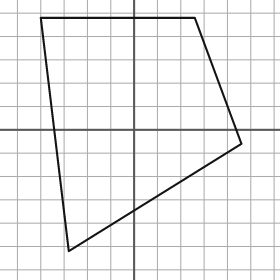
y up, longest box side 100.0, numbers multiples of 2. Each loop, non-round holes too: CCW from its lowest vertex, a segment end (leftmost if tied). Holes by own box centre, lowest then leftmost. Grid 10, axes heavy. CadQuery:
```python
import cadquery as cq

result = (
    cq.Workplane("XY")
    .moveTo(-28.0, -52.0)
    .lineTo(46.0, -6.0)
    .lineTo(26.0, 48.0)
    .lineTo(-40.0, 48.0)
    .close()
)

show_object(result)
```